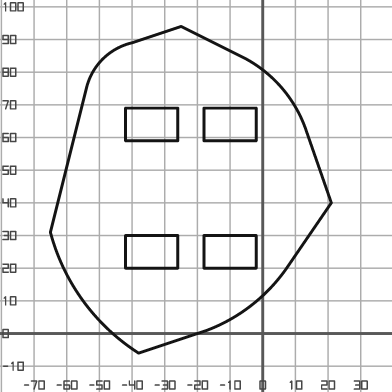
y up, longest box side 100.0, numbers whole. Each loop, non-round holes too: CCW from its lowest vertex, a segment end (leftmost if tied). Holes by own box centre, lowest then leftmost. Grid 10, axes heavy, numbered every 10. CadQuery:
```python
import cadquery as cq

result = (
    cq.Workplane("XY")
    .moveTo(-38.0, -6.0)
    .lineTo(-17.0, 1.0)
    .threePointArc((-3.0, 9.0), (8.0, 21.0))
    .lineTo(21.0, 40.0)
    .lineTo(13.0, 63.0)
    .threePointArc((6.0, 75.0), (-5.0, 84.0))
    .lineTo(-25.0, 94.0)
    .lineTo(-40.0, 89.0)
    .threePointArc((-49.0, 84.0), (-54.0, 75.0))
    .lineTo(-65.0, 31.0)
    .threePointArc((-55.0, 10.0), (-38.0, -6.0))
    .close()
    .moveTo(-42.0, 20.0)
    .lineTo(-26.0, 20.0)
    .lineTo(-26.0, 30.0)
    .lineTo(-42.0, 30.0)
    .close()
    .moveTo(-18.0, 20.0)
    .lineTo(-2.0, 20.0)
    .lineTo(-2.0, 30.0)
    .lineTo(-18.0, 30.0)
    .close()
    .moveTo(-42.0, 59.0)
    .lineTo(-26.0, 59.0)
    .lineTo(-26.0, 69.0)
    .lineTo(-42.0, 69.0)
    .close()
    .moveTo(-18.0, 59.0)
    .lineTo(-2.0, 59.0)
    .lineTo(-2.0, 69.0)
    .lineTo(-18.0, 69.0)
    .close()
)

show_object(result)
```